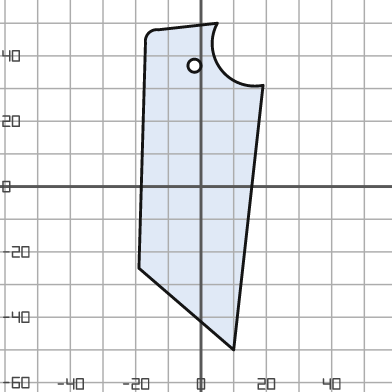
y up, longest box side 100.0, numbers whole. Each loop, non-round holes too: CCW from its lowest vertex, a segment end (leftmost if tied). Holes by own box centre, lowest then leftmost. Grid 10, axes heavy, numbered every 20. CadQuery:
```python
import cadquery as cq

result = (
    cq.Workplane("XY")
    .moveTo(10.0, -50.0)
    .lineTo(19.0, 31.0)
    .threePointArc((6.0, 36.0), (5.0, 50.0))
    .lineTo(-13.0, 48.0)
    .threePointArc((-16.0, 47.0), (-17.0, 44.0))
    .lineTo(-19.0, -25.0)
    .close()
    .moveTo(-2.0, 37.0)
    .circle(2.0)
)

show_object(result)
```